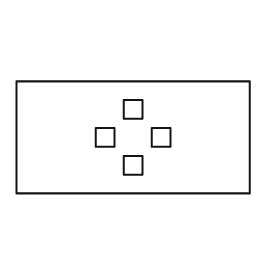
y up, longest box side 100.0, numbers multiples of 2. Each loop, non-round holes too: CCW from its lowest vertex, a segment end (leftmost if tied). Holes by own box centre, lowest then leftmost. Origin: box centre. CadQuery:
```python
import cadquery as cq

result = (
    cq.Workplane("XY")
    .moveTo(-50.0, -24.0)
    .lineTo(50.0, -24.0)
    .lineTo(50.0, 24.0)
    .lineTo(-50.0, 24.0)
    .close()
    .moveTo(-4.0, -16.0)
    .lineTo(4.0, -16.0)
    .lineTo(4.0, -8.0)
    .lineTo(-4.0, -8.0)
    .close()
    .moveTo(-16.0, -4.0)
    .lineTo(-8.0, -4.0)
    .lineTo(-8.0, 4.0)
    .lineTo(-16.0, 4.0)
    .close()
    .moveTo(8.0, -4.0)
    .lineTo(16.0, -4.0)
    .lineTo(16.0, 4.0)
    .lineTo(8.0, 4.0)
    .close()
    .moveTo(-4.0, 8.0)
    .lineTo(4.0, 8.0)
    .lineTo(4.0, 16.0)
    .lineTo(-4.0, 16.0)
    .close()
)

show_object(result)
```